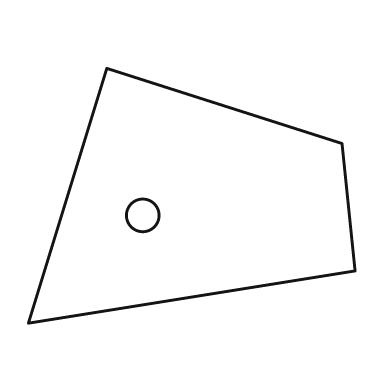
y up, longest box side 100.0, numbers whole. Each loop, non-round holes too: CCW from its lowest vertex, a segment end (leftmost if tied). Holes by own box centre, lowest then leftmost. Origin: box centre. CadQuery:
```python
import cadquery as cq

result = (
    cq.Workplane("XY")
    .moveTo(-50.0, -39.0)
    .lineTo(50.0, -23.0)
    .lineTo(46.0, 16.0)
    .lineTo(-26.0, 39.0)
    .close()
    .moveTo(-15.0, -6.0)
    .circle(5.0)
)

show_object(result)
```